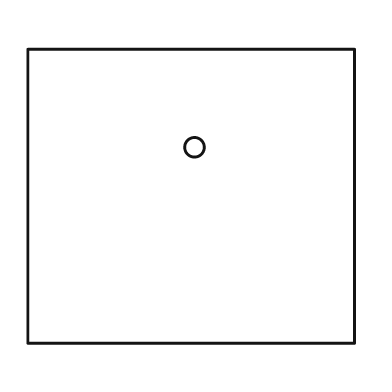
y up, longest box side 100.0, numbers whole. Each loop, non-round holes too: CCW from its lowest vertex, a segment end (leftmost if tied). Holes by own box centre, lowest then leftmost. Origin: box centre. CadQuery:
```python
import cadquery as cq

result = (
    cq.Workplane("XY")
    .moveTo(-50.0, -45.0)
    .lineTo(50.0, -45.0)
    .lineTo(50.0, 45.0)
    .lineTo(-50.0, 45.0)
    .close()
    .moveTo(1.0, 15.0)
    .circle(3.0)
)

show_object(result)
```